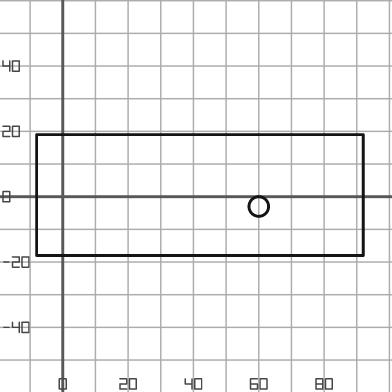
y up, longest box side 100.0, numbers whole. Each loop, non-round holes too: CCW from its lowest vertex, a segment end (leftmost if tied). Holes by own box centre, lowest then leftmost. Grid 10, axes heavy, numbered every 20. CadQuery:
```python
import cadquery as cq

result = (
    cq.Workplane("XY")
    .moveTo(-8.0, -18.0)
    .lineTo(92.0, -18.0)
    .lineTo(92.0, 19.0)
    .lineTo(-8.0, 19.0)
    .close()
    .moveTo(60.0, -3.0)
    .circle(3.0)
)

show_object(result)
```